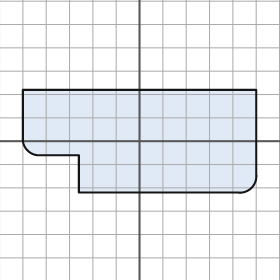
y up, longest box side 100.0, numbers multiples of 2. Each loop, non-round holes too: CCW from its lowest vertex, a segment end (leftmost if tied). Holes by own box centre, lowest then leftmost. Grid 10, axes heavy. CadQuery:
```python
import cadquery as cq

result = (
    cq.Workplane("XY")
    .moveTo(-26.0, -22.0)
    .lineTo(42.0, -22.0)
    .threePointArc((48.0, -20.0), (50.0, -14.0))
    .lineTo(50.0, 22.0)
    .lineTo(-50.0, 22.0)
    .lineTo(-50.0, 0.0)
    .threePointArc((-48.0, -4.0), (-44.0, -6.0))
    .lineTo(-26.0, -6.0)
    .close()
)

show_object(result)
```